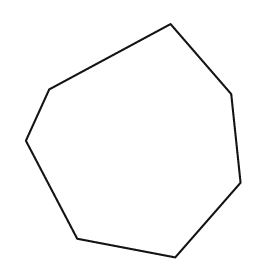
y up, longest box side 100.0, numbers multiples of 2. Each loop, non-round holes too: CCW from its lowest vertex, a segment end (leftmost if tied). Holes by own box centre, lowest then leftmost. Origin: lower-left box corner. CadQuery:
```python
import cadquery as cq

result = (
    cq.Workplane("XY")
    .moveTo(64.0, 0.0)
    .lineTo(92.0, 32.0)
    .lineTo(88.0, 70.0)
    .lineTo(62.0, 100.0)
    .lineTo(10.0, 72.0)
    .lineTo(0.0, 50.0)
    .lineTo(22.0, 8.0)
    .close()
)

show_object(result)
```